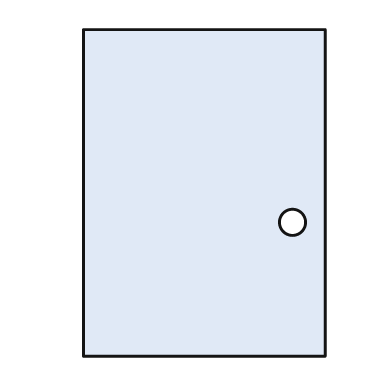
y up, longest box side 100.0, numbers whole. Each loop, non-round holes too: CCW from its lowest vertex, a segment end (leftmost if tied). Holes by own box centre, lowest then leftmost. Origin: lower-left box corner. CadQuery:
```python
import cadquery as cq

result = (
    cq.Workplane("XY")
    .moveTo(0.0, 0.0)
    .lineTo(74.0, 0.0)
    .lineTo(74.0, 100.0)
    .lineTo(0.0, 100.0)
    .close()
    .moveTo(64.0, 41.0)
    .circle(4.0)
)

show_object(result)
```